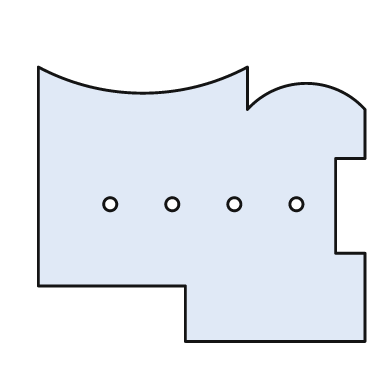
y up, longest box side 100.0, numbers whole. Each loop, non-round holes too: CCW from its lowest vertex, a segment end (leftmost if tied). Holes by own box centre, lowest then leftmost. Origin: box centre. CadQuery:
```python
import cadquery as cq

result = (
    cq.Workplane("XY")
    .moveTo(-5.0, -42.0)
    .lineTo(50.0, -42.0)
    .lineTo(50.0, -15.0)
    .lineTo(41.0, -15.0)
    .lineTo(41.0, 14.0)
    .lineTo(50.0, 14.0)
    .lineTo(50.0, 29.0)
    .threePointArc((32.0, 37.0), (14.0, 29.0))
    .lineTo(14.0, 42.0)
    .threePointArc((-18.0, 34.0), (-50.0, 42.0))
    .lineTo(-50.0, -25.0)
    .lineTo(-5.0, -25.0)
    .close()
    .moveTo(-28.0, 0.0)
    .circle(2.0)
    .moveTo(-9.0, 0.0)
    .circle(2.0)
    .moveTo(10.0, 0.0)
    .circle(2.0)
    .moveTo(29.0, 0.0)
    .circle(2.0)
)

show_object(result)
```